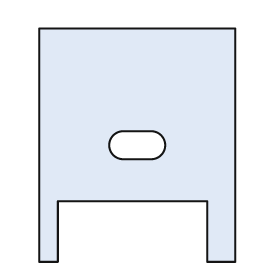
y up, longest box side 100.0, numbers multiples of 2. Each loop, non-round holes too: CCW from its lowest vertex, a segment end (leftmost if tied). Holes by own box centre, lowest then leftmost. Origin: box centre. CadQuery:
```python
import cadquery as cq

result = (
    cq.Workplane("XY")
    .moveTo(-42.0, -50.0)
    .lineTo(-34.0, -50.0)
    .lineTo(-34.0, -24.0)
    .lineTo(30.0, -24.0)
    .lineTo(30.0, -50.0)
    .lineTo(42.0, -50.0)
    .lineTo(42.0, 50.0)
    .lineTo(-42.0, 50.0)
    .close()
    .moveTo(-6.0, -6.0)
    .lineTo(6.0, -6.0)
    .threePointArc((12.0, 0.0), (6.0, 6.0))
    .lineTo(-6.0, 6.0)
    .threePointArc((-12.0, 0.0), (-6.0, -6.0))
    .close()
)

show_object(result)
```